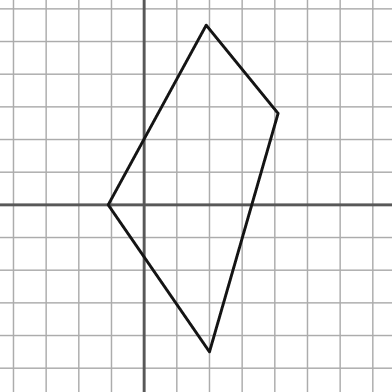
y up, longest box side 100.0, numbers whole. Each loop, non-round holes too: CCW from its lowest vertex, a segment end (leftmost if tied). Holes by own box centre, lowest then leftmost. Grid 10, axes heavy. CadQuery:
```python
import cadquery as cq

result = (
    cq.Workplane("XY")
    .moveTo(20.0, -45.0)
    .lineTo(41.0, 28.0)
    .lineTo(19.0, 55.0)
    .lineTo(-11.0, 0.0)
    .close()
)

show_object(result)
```